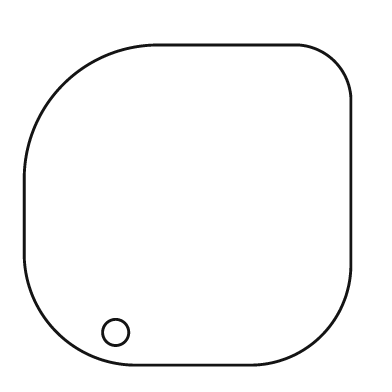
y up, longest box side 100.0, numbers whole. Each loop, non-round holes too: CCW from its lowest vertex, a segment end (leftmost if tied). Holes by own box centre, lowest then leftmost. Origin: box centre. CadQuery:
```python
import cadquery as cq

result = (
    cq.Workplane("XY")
    .moveTo(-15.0, -49.0)
    .lineTo(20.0, -49.0)
    .threePointArc((41.0, -40.0), (50.0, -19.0))
    .lineTo(50.0, 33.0)
    .threePointArc((45.0, 44.0), (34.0, 49.0))
    .lineTo(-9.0, 49.0)
    .threePointArc((-38.0, 37.0), (-50.0, 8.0))
    .lineTo(-50.0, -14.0)
    .threePointArc((-40.0, -39.0), (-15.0, -49.0))
    .close()
    .moveTo(-22.0, -39.0)
    .circle(4.0)
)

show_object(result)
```